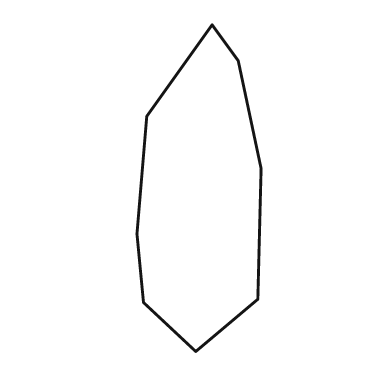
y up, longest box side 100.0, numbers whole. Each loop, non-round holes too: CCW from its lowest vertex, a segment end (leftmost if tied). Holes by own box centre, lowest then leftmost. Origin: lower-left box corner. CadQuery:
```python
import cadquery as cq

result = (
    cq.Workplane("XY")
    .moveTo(18.0, 0.0)
    .lineTo(37.0, 16.0)
    .lineTo(38.0, 56.0)
    .lineTo(31.0, 89.0)
    .lineTo(23.0, 100.0)
    .lineTo(3.0, 72.0)
    .lineTo(0.0, 36.0)
    .lineTo(2.0, 15.0)
    .close()
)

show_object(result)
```